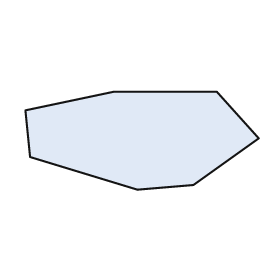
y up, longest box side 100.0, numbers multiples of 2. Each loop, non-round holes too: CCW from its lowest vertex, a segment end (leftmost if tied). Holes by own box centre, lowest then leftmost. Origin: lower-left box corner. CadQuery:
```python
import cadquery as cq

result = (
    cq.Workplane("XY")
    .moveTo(48.0, 0.0)
    .lineTo(72.0, 2.0)
    .lineTo(100.0, 22.0)
    .lineTo(82.0, 42.0)
    .lineTo(38.0, 42.0)
    .lineTo(0.0, 34.0)
    .lineTo(2.0, 14.0)
    .close()
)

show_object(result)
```